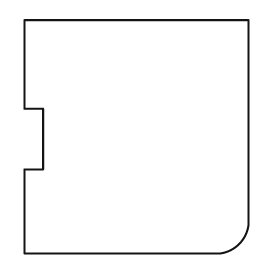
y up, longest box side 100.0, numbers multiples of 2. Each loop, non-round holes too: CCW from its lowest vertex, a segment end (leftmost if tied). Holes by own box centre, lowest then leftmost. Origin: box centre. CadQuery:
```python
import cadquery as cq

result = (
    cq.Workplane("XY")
    .moveTo(-48.0, -50.0)
    .lineTo(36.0, -50.0)
    .threePointArc((44.0, -46.0), (48.0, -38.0))
    .lineTo(48.0, 50.0)
    .lineTo(-48.0, 50.0)
    .lineTo(-48.0, 12.0)
    .lineTo(-40.0, 12.0)
    .lineTo(-40.0, -14.0)
    .lineTo(-48.0, -14.0)
    .close()
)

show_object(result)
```